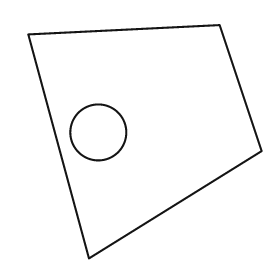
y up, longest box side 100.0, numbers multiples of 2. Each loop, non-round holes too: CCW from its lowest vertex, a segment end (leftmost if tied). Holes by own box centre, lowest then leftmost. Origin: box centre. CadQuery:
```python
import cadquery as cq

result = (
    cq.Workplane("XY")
    .moveTo(-24.0, -50.0)
    .lineTo(50.0, -4.0)
    .lineTo(32.0, 50.0)
    .lineTo(-50.0, 46.0)
    .close()
    .moveTo(-20.0, 4.0)
    .circle(12.0)
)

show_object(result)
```